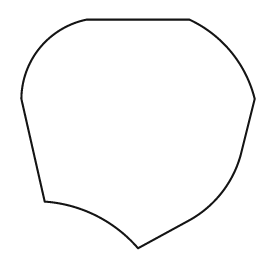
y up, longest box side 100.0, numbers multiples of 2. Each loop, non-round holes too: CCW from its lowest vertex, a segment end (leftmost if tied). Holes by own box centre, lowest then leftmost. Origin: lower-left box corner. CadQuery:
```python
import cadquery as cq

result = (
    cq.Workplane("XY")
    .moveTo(50.0, 0.0)
    .lineTo(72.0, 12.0)
    .threePointArc((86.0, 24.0), (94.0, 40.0))
    .lineTo(100.0, 64.0)
    .threePointArc((90.0, 84.0), (72.0, 98.0))
    .lineTo(28.0, 98.0)
    .threePointArc((8.0, 86.0), (0.0, 64.0))
    .lineTo(10.0, 20.0)
    .threePointArc((32.0, 14.0), (50.0, 0.0))
    .close()
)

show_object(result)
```